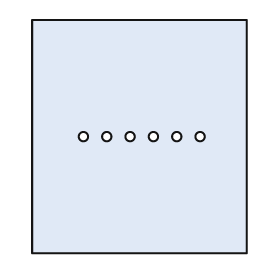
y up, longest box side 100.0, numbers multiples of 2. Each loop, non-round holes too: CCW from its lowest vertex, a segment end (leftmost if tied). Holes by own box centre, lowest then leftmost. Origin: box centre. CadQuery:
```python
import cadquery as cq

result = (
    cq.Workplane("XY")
    .moveTo(-46.0, -50.0)
    .lineTo(46.0, -50.0)
    .lineTo(46.0, 50.0)
    .lineTo(-46.0, 50.0)
    .close()
    .moveTo(-24.0, 0.0)
    .circle(2.0)
    .moveTo(-14.0, 0.0)
    .circle(2.0)
    .moveTo(-4.0, 0.0)
    .circle(2.0)
    .moveTo(6.0, 0.0)
    .circle(2.0)
    .moveTo(16.0, 0.0)
    .circle(2.0)
    .moveTo(26.0, 0.0)
    .circle(2.0)
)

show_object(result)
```